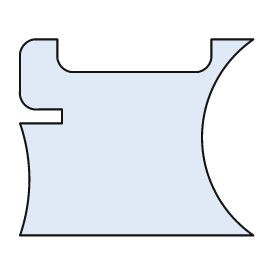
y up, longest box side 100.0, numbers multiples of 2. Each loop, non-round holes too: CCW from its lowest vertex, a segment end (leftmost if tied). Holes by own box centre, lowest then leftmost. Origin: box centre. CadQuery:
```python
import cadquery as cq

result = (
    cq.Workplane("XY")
    .moveTo(-50.0, -42.0)
    .lineTo(50.0, -42.0)
    .threePointArc((28.0, 0.0), (50.0, 42.0))
    .lineTo(32.0, 42.0)
    .lineTo(32.0, 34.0)
    .threePointArc((30.0, 30.0), (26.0, 28.0))
    .lineTo(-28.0, 28.0)
    .threePointArc((-32.0, 30.0), (-34.0, 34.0))
    .lineTo(-34.0, 42.0)
    .lineTo(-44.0, 42.0)
    .threePointArc((-48.0, 40.0), (-50.0, 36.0))
    .lineTo(-50.0, 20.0)
    .threePointArc((-48.0, 14.0), (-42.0, 12.0))
    .lineTo(-32.0, 12.0)
    .lineTo(-32.0, 6.0)
    .lineTo(-50.0, 6.0)
    .threePointArc((-46.0, -18.0), (-50.0, -42.0))
    .close()
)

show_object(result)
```